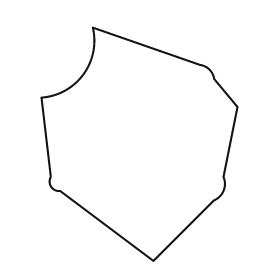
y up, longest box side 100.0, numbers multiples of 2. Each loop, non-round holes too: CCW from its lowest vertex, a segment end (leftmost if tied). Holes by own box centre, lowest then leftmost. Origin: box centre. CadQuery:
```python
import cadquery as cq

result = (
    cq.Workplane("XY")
    .moveTo(6.0, -50.0)
    .lineTo(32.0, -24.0)
    .threePointArc((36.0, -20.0), (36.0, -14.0))
    .lineTo(42.0, 16.0)
    .lineTo(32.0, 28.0)
    .threePointArc((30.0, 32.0), (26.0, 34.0))
    .lineTo(-20.0, 50.0)
    .threePointArc((-24.0, 30.0), (-42.0, 20.0))
    .lineTo(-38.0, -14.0)
    .threePointArc((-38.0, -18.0), (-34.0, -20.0))
    .close()
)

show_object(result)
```